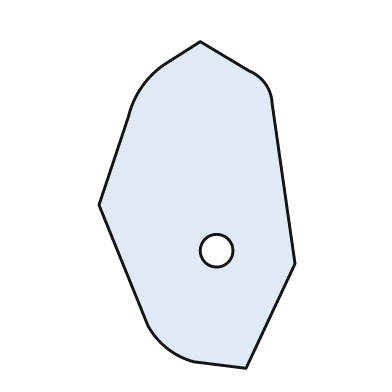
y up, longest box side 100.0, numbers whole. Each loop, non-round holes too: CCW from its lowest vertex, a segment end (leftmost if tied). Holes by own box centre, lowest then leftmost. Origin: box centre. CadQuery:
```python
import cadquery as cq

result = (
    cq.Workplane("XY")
    .moveTo(15.0, -50.0)
    .lineTo(30.0, -18.0)
    .lineTo(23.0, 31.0)
    .threePointArc((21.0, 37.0), (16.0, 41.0))
    .lineTo(1.0, 50.0)
    .lineTo(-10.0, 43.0)
    .threePointArc((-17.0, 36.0), (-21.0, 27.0))
    .lineTo(-30.0, 0.0)
    .lineTo(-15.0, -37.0)
    .threePointArc((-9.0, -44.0), (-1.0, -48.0))
    .close()
    .moveTo(6.0, -14.0)
    .circle(5.0)
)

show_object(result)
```